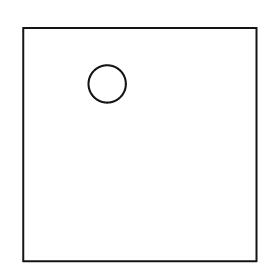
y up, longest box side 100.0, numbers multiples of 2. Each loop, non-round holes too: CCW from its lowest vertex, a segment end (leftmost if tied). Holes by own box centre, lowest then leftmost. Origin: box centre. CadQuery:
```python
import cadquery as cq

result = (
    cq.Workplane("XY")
    .moveTo(-50.0, -50.0)
    .lineTo(50.0, -50.0)
    .lineTo(50.0, 50.0)
    .lineTo(-50.0, 50.0)
    .close()
    .moveTo(-14.0, 26.0)
    .circle(8.0)
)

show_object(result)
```